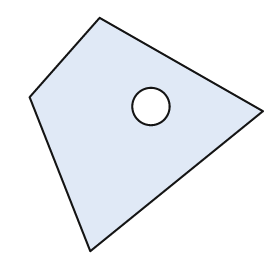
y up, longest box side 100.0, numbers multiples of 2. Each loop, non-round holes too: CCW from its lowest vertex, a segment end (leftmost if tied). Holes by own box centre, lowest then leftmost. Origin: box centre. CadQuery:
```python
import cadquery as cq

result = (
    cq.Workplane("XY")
    .moveTo(-24.0, -50.0)
    .lineTo(50.0, 10.0)
    .lineTo(-20.0, 50.0)
    .lineTo(-50.0, 16.0)
    .close()
    .moveTo(2.0, 12.0)
    .circle(8.0)
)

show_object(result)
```